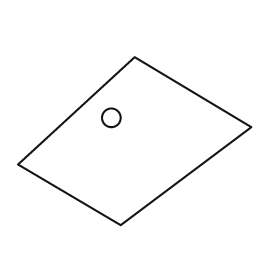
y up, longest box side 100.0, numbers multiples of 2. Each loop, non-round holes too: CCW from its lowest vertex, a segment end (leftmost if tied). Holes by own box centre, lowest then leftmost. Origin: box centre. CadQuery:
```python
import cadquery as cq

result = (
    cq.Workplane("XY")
    .moveTo(-6.0, -36.0)
    .lineTo(50.0, 6.0)
    .lineTo(0.0, 36.0)
    .lineTo(-50.0, -10.0)
    .close()
    .moveTo(-10.0, 10.0)
    .circle(4.0)
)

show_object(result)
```